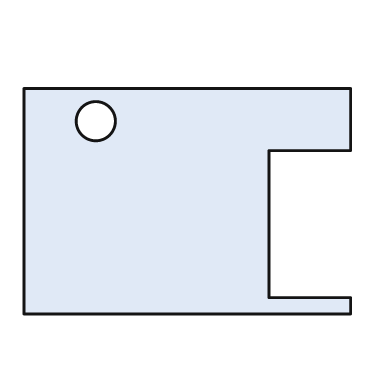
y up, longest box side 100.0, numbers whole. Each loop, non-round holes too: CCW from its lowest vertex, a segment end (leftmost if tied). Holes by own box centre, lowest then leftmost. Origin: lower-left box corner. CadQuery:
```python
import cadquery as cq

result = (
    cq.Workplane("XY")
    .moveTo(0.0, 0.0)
    .lineTo(100.0, 0.0)
    .lineTo(100.0, 5.0)
    .lineTo(75.0, 5.0)
    .lineTo(75.0, 50.0)
    .lineTo(100.0, 50.0)
    .lineTo(100.0, 69.0)
    .lineTo(0.0, 69.0)
    .close()
    .moveTo(22.0, 59.0)
    .circle(6.0)
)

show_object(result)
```